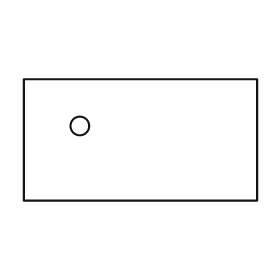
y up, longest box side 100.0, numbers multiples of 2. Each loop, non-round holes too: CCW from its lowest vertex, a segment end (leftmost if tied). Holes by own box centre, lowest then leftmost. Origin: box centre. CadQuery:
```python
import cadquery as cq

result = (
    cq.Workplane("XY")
    .moveTo(-50.0, -26.0)
    .lineTo(50.0, -26.0)
    .lineTo(50.0, 26.0)
    .lineTo(-50.0, 26.0)
    .close()
    .moveTo(-26.0, 6.0)
    .circle(4.0)
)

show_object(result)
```